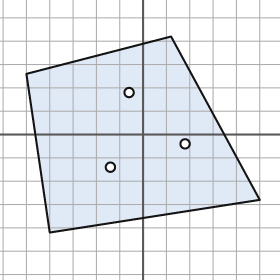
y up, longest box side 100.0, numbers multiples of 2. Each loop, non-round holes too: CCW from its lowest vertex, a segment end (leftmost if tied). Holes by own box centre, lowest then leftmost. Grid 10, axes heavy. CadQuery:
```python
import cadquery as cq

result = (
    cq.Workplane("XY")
    .moveTo(-40.0, -42.0)
    .lineTo(50.0, -28.0)
    .lineTo(12.0, 42.0)
    .lineTo(-50.0, 26.0)
    .close()
    .moveTo(-14.0, -14.0)
    .circle(2.0)
    .moveTo(18.0, -4.0)
    .circle(2.0)
    .moveTo(-6.0, 18.0)
    .circle(2.0)
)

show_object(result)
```